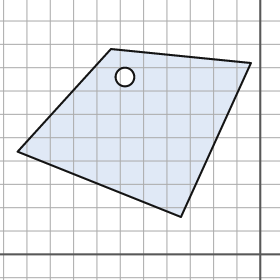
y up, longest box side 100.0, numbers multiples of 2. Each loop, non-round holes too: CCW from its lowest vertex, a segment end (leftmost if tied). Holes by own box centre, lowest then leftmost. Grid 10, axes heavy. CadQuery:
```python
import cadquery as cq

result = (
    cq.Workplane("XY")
    .moveTo(-34.0, 16.0)
    .lineTo(-4.0, 82.0)
    .lineTo(-64.0, 88.0)
    .lineTo(-104.0, 44.0)
    .close()
    .moveTo(-58.0, 76.0)
    .circle(4.0)
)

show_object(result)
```